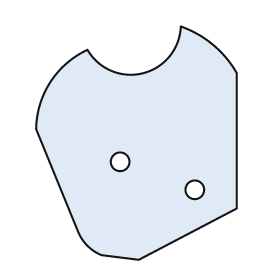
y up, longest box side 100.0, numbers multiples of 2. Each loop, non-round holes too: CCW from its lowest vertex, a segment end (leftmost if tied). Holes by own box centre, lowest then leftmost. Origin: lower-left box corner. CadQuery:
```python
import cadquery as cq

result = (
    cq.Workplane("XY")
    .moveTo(44.0, 0.0)
    .lineTo(86.0, 22.0)
    .lineTo(86.0, 80.0)
    .threePointArc((76.0, 92.0), (62.0, 100.0))
    .threePointArc((46.0, 80.0), (22.0, 90.0))
    .threePointArc((6.0, 76.0), (0.0, 56.0))
    .lineTo(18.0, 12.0)
    .threePointArc((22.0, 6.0), (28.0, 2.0))
    .close()
    .moveTo(68.0, 30.0)
    .circle(4.0)
    .moveTo(36.0, 42.0)
    .circle(4.0)
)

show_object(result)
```